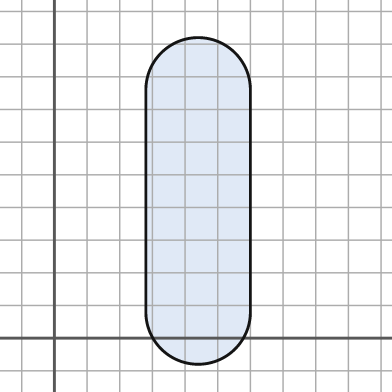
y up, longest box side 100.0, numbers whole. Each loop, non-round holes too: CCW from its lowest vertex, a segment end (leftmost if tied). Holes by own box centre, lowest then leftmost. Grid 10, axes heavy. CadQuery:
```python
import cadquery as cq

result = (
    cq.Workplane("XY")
    .moveTo(28.0, 8.0)
    .threePointArc((44.0, -8.0), (60.0, 8.0))
    .lineTo(60.0, 76.0)
    .threePointArc((44.0, 92.0), (28.0, 76.0))
    .close()
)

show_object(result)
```